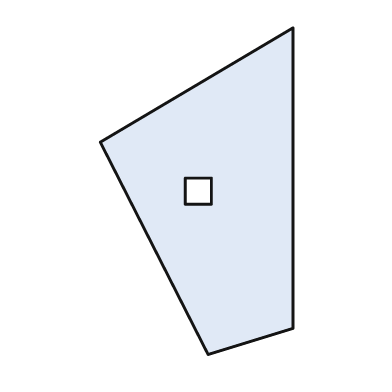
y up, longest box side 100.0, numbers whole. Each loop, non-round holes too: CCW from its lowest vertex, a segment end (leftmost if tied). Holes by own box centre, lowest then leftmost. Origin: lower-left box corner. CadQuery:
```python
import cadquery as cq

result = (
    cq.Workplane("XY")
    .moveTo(33.0, 0.0)
    .lineTo(59.0, 8.0)
    .lineTo(59.0, 100.0)
    .lineTo(0.0, 65.0)
    .close()
    .moveTo(26.0, 46.0)
    .lineTo(34.0, 46.0)
    .lineTo(34.0, 54.0)
    .lineTo(26.0, 54.0)
    .close()
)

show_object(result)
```